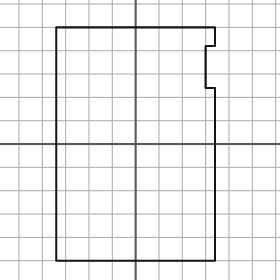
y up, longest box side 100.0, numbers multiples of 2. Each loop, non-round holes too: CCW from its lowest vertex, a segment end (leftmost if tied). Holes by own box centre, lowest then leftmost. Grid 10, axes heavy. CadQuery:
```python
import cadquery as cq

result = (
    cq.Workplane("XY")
    .moveTo(-34.0, -50.0)
    .lineTo(34.0, -50.0)
    .lineTo(34.0, 24.0)
    .lineTo(30.0, 24.0)
    .lineTo(30.0, 42.0)
    .lineTo(34.0, 42.0)
    .lineTo(34.0, 50.0)
    .lineTo(-34.0, 50.0)
    .close()
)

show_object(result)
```